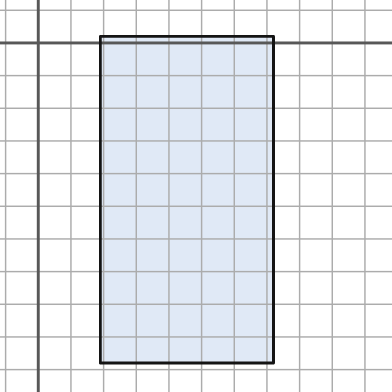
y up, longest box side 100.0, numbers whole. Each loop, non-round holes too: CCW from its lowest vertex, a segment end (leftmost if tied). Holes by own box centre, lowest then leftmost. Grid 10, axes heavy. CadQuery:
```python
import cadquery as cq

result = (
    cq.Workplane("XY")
    .moveTo(19.0, -98.0)
    .lineTo(72.0, -98.0)
    .lineTo(72.0, 2.0)
    .lineTo(19.0, 2.0)
    .close()
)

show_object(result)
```